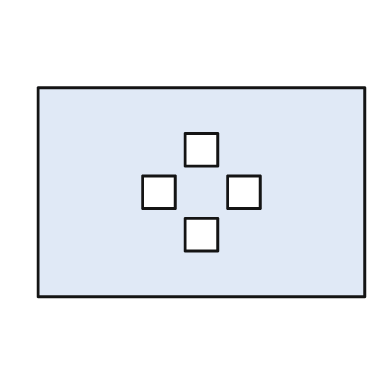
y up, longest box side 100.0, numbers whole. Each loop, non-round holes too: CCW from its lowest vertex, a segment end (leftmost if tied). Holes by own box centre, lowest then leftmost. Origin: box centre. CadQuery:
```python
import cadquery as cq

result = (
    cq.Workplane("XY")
    .moveTo(-50.0, -32.0)
    .lineTo(50.0, -32.0)
    .lineTo(50.0, 32.0)
    .lineTo(-50.0, 32.0)
    .close()
    .moveTo(-5.0, -18.0)
    .lineTo(5.0, -18.0)
    .lineTo(5.0, -8.0)
    .lineTo(-5.0, -8.0)
    .close()
    .moveTo(-18.0, -5.0)
    .lineTo(-8.0, -5.0)
    .lineTo(-8.0, 5.0)
    .lineTo(-18.0, 5.0)
    .close()
    .moveTo(8.0, -5.0)
    .lineTo(18.0, -5.0)
    .lineTo(18.0, 5.0)
    .lineTo(8.0, 5.0)
    .close()
    .moveTo(-5.0, 8.0)
    .lineTo(5.0, 8.0)
    .lineTo(5.0, 18.0)
    .lineTo(-5.0, 18.0)
    .close()
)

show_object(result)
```